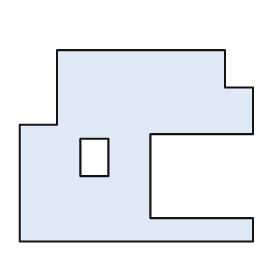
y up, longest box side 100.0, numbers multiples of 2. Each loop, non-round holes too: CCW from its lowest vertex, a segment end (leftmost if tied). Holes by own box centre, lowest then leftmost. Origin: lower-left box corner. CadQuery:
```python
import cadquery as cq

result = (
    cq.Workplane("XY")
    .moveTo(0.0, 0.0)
    .lineTo(100.0, 0.0)
    .lineTo(100.0, 10.0)
    .lineTo(56.0, 10.0)
    .lineTo(56.0, 46.0)
    .lineTo(100.0, 46.0)
    .lineTo(100.0, 66.0)
    .lineTo(88.0, 66.0)
    .lineTo(88.0, 82.0)
    .lineTo(16.0, 82.0)
    .lineTo(16.0, 50.0)
    .lineTo(0.0, 50.0)
    .close()
    .moveTo(26.0, 28.0)
    .lineTo(38.0, 28.0)
    .lineTo(38.0, 44.0)
    .lineTo(26.0, 44.0)
    .close()
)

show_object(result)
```